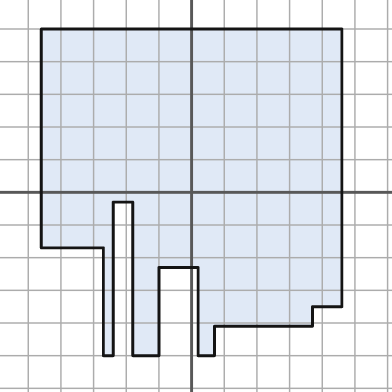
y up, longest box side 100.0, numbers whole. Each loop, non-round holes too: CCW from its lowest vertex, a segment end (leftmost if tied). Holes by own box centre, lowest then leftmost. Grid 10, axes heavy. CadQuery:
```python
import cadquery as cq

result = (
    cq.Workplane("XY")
    .moveTo(-27.0, -50.0)
    .lineTo(-24.0, -50.0)
    .lineTo(-24.0, -3.0)
    .lineTo(-18.0, -3.0)
    .lineTo(-18.0, -50.0)
    .lineTo(-10.0, -50.0)
    .lineTo(-10.0, -23.0)
    .lineTo(2.0, -23.0)
    .lineTo(2.0, -50.0)
    .lineTo(7.0, -50.0)
    .lineTo(7.0, -41.0)
    .lineTo(37.0, -41.0)
    .lineTo(37.0, -35.0)
    .lineTo(46.0, -35.0)
    .lineTo(46.0, 50.0)
    .lineTo(-46.0, 50.0)
    .lineTo(-46.0, -17.0)
    .lineTo(-27.0, -17.0)
    .close()
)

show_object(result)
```